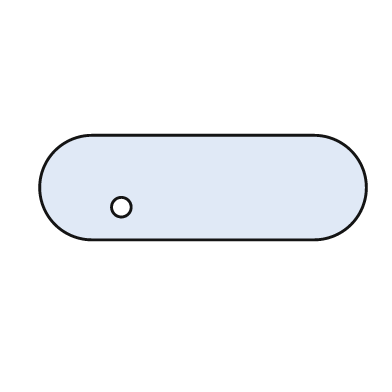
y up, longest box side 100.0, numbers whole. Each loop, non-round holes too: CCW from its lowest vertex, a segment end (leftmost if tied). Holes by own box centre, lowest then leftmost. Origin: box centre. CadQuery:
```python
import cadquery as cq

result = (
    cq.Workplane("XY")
    .moveTo(-34.0, -16.0)
    .lineTo(34.0, -16.0)
    .threePointArc((50.0, 0.0), (34.0, 16.0))
    .lineTo(-34.0, 16.0)
    .threePointArc((-50.0, 0.0), (-34.0, -16.0))
    .close()
    .moveTo(-25.0, -6.0)
    .circle(3.0)
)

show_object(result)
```